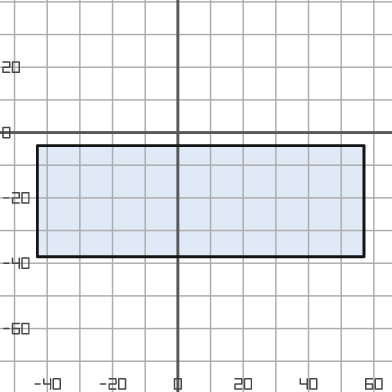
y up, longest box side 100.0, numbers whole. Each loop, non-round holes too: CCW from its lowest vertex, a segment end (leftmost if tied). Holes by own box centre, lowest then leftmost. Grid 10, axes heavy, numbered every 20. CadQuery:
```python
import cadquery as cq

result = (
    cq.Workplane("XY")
    .moveTo(-43.0, -38.0)
    .lineTo(57.0, -38.0)
    .lineTo(57.0, -4.0)
    .lineTo(-43.0, -4.0)
    .close()
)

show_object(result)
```